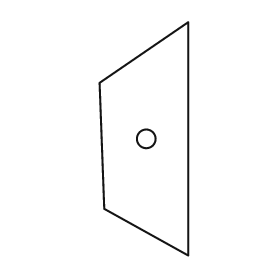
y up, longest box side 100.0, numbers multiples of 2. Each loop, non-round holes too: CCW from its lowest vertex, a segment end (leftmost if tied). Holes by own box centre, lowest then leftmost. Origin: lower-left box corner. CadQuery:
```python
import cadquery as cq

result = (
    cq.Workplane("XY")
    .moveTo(38.0, 0.0)
    .lineTo(38.0, 100.0)
    .lineTo(0.0, 74.0)
    .lineTo(2.0, 20.0)
    .close()
    .moveTo(20.0, 50.0)
    .circle(4.0)
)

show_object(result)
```